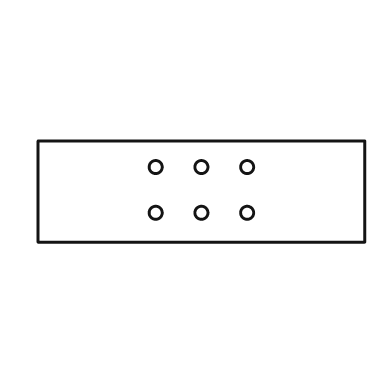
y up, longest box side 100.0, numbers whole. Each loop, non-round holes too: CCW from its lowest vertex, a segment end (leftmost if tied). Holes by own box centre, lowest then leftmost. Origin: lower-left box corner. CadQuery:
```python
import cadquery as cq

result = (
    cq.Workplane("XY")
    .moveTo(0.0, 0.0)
    .lineTo(100.0, 0.0)
    .lineTo(100.0, 31.0)
    .lineTo(0.0, 31.0)
    .close()
    .moveTo(36.0, 9.0)
    .circle(2.0)
    .moveTo(50.0, 9.0)
    .circle(2.0)
    .moveTo(64.0, 9.0)
    .circle(2.0)
    .moveTo(36.0, 23.0)
    .circle(2.0)
    .moveTo(50.0, 23.0)
    .circle(2.0)
    .moveTo(64.0, 23.0)
    .circle(2.0)
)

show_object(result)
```